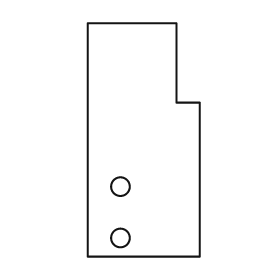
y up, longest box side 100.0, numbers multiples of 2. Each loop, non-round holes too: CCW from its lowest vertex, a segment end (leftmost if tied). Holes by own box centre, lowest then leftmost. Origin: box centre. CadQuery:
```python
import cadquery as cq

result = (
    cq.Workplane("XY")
    .moveTo(-24.0, -50.0)
    .lineTo(24.0, -50.0)
    .lineTo(24.0, 16.0)
    .lineTo(14.0, 16.0)
    .lineTo(14.0, 50.0)
    .lineTo(-24.0, 50.0)
    .close()
    .moveTo(-10.0, -42.0)
    .circle(4.0)
    .moveTo(-10.0, -20.0)
    .circle(4.0)
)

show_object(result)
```